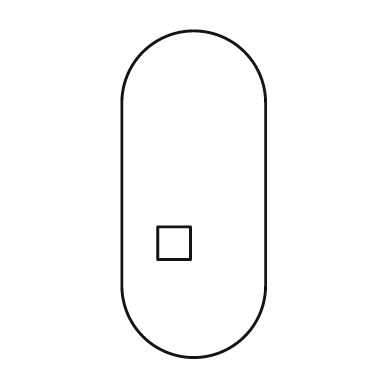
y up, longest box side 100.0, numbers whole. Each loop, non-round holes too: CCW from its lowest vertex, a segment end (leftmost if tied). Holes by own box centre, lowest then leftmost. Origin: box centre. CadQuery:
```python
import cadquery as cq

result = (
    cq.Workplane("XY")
    .moveTo(-22.0, -28.0)
    .threePointArc((0.0, -50.0), (22.0, -28.0))
    .lineTo(22.0, 28.0)
    .threePointArc((0.0, 50.0), (-22.0, 28.0))
    .close()
    .moveTo(-11.0, -20.0)
    .lineTo(-1.0, -20.0)
    .lineTo(-1.0, -10.0)
    .lineTo(-11.0, -10.0)
    .close()
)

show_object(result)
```